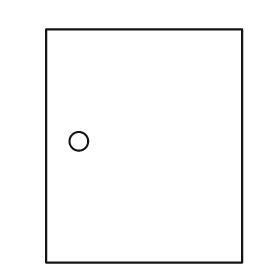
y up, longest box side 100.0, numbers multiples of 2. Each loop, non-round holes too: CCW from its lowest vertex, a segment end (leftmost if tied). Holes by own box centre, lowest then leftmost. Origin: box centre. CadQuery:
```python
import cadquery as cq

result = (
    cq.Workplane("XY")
    .moveTo(-42.0, -50.0)
    .lineTo(42.0, -50.0)
    .lineTo(42.0, 50.0)
    .lineTo(-42.0, 50.0)
    .close()
    .moveTo(-28.0, 2.0)
    .circle(4.0)
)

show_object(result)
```